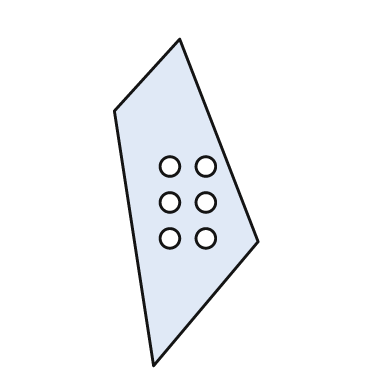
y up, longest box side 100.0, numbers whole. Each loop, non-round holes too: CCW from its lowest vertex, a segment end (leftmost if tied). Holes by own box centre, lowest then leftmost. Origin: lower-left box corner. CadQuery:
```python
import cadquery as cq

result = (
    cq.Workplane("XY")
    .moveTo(12.0, 0.0)
    .lineTo(44.0, 38.0)
    .lineTo(20.0, 100.0)
    .lineTo(0.0, 78.0)
    .close()
    .moveTo(17.0, 39.0)
    .circle(3.0)
    .moveTo(28.0, 39.0)
    .circle(3.0)
    .moveTo(17.0, 50.0)
    .circle(3.0)
    .moveTo(28.0, 50.0)
    .circle(3.0)
    .moveTo(17.0, 61.0)
    .circle(3.0)
    .moveTo(28.0, 61.0)
    .circle(3.0)
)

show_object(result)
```